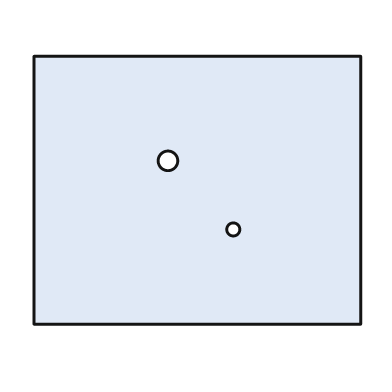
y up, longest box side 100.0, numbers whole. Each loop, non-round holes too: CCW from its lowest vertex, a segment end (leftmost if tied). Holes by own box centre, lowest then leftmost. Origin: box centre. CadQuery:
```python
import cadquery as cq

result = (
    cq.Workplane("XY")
    .moveTo(-50.0, -41.0)
    .lineTo(50.0, -41.0)
    .lineTo(50.0, 41.0)
    .lineTo(-50.0, 41.0)
    .close()
    .moveTo(11.0, -12.0)
    .circle(2.0)
    .moveTo(-9.0, 9.0)
    .circle(3.0)
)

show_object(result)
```